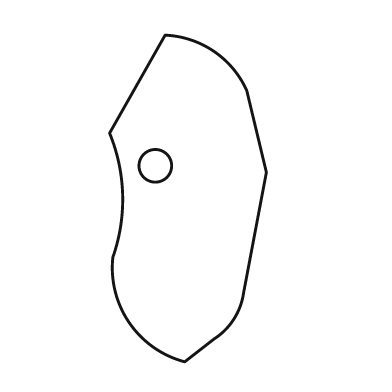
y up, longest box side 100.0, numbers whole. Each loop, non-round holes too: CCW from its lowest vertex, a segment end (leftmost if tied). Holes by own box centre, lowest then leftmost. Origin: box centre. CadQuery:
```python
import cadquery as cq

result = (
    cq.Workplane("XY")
    .moveTo(-1.0, -50.0)
    .lineTo(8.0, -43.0)
    .threePointArc((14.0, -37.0), (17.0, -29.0))
    .lineTo(24.0, 8.0)
    .lineTo(18.0, 33.0)
    .threePointArc((8.0, 45.0), (-7.0, 50.0))
    .lineTo(-24.0, 20.0)
    .threePointArc((-20.0, 1.0), (-23.0, -18.0))
    .threePointArc((-18.0, -38.0), (-1.0, -50.0))
    .close()
    .moveTo(-10.0, 10.0)
    .circle(5.0)
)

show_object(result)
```